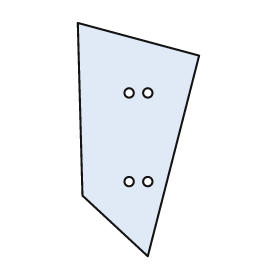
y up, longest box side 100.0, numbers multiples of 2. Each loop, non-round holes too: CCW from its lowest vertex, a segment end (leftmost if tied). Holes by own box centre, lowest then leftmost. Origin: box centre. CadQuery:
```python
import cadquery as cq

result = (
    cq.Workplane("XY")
    .moveTo(4.0, -50.0)
    .lineTo(26.0, 36.0)
    .lineTo(-26.0, 50.0)
    .lineTo(-24.0, -24.0)
    .close()
    .moveTo(-4.0, -18.0)
    .circle(2.0)
    .moveTo(4.0, -18.0)
    .circle(2.0)
    .moveTo(-4.0, 20.0)
    .circle(2.0)
    .moveTo(4.0, 20.0)
    .circle(2.0)
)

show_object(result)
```